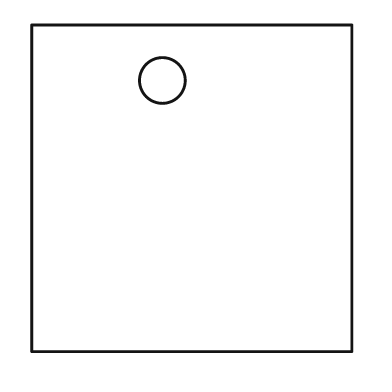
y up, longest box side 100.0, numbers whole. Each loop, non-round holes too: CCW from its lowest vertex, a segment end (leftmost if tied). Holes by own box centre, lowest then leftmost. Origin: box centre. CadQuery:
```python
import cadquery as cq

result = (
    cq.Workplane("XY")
    .moveTo(-49.0, -50.0)
    .lineTo(49.0, -50.0)
    .lineTo(49.0, 50.0)
    .lineTo(-49.0, 50.0)
    .close()
    .moveTo(-9.0, 33.0)
    .circle(7.0)
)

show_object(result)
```